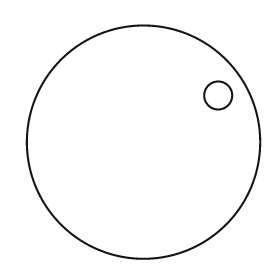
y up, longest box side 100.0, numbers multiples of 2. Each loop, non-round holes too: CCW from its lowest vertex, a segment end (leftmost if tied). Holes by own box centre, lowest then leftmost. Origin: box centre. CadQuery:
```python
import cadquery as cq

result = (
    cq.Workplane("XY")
    .moveTo(0.0, 0.0)
    .circle(50.0)
    .moveTo(32.0, 20.0)
    .circle(6.0)
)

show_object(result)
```